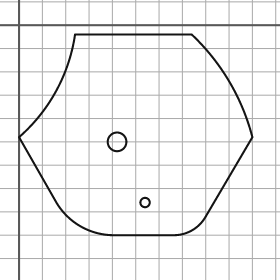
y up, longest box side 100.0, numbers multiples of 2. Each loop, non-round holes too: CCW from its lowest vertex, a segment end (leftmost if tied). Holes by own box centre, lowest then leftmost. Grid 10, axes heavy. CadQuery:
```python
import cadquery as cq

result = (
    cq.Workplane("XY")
    .moveTo(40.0, -90.0)
    .lineTo(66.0, -90.0)
    .threePointArc((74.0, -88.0), (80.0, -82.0))
    .lineTo(100.0, -48.0)
    .threePointArc((90.0, -24.0), (74.0, -4.0))
    .lineTo(24.0, -4.0)
    .threePointArc((16.0, -28.0), (0.0, -48.0))
    .lineTo(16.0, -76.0)
    .threePointArc((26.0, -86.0), (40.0, -90.0))
    .close()
    .moveTo(54.0, -76.0)
    .circle(2.0)
    .moveTo(42.0, -50.0)
    .circle(4.0)
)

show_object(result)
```